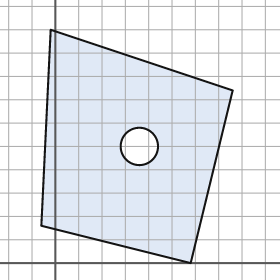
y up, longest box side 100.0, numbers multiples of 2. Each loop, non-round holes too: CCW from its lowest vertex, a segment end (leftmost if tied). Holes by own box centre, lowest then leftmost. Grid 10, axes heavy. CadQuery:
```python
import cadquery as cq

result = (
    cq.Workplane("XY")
    .moveTo(58.0, 0.0)
    .lineTo(76.0, 74.0)
    .lineTo(-2.0, 100.0)
    .lineTo(-6.0, 16.0)
    .close()
    .moveTo(36.0, 50.0)
    .circle(8.0)
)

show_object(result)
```